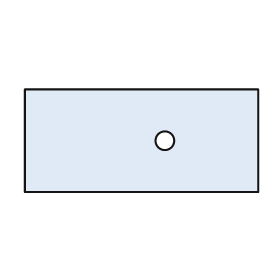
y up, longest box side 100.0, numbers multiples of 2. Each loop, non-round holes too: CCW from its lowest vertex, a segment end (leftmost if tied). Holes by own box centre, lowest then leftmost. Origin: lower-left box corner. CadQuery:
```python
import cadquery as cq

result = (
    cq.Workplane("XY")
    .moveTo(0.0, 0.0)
    .lineTo(100.0, 0.0)
    .lineTo(100.0, 44.0)
    .lineTo(0.0, 44.0)
    .close()
    .moveTo(60.0, 22.0)
    .circle(4.0)
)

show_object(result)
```